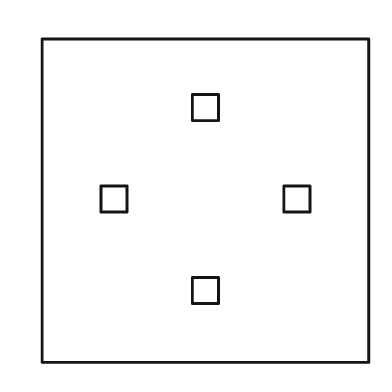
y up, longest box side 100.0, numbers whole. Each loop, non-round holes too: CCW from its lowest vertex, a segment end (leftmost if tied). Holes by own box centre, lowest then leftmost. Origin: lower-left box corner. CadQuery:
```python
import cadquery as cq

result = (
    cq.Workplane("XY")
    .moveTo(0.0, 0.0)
    .lineTo(100.0, 0.0)
    .lineTo(100.0, 99.0)
    .lineTo(0.0, 99.0)
    .close()
    .moveTo(46.0, 18.0)
    .lineTo(54.0, 18.0)
    .lineTo(54.0, 26.0)
    .lineTo(46.0, 26.0)
    .close()
    .moveTo(18.0, 46.0)
    .lineTo(26.0, 46.0)
    .lineTo(26.0, 54.0)
    .lineTo(18.0, 54.0)
    .close()
    .moveTo(74.0, 46.0)
    .lineTo(82.0, 46.0)
    .lineTo(82.0, 54.0)
    .lineTo(74.0, 54.0)
    .close()
    .moveTo(46.0, 74.0)
    .lineTo(54.0, 74.0)
    .lineTo(54.0, 82.0)
    .lineTo(46.0, 82.0)
    .close()
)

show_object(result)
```